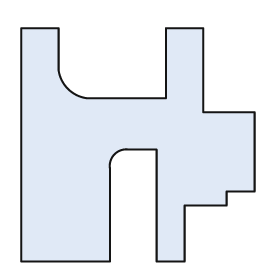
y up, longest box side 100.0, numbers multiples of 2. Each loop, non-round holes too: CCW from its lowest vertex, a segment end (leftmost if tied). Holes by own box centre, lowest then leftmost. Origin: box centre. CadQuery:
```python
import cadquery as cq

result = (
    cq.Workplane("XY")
    .moveTo(-50.0, -50.0)
    .lineTo(-12.0, -50.0)
    .lineTo(-12.0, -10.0)
    .threePointArc((-10.0, -4.0), (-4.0, -2.0))
    .lineTo(8.0, -2.0)
    .lineTo(8.0, -50.0)
    .lineTo(20.0, -50.0)
    .lineTo(20.0, -26.0)
    .lineTo(38.0, -26.0)
    .lineTo(38.0, -20.0)
    .lineTo(50.0, -20.0)
    .lineTo(50.0, 14.0)
    .lineTo(28.0, 14.0)
    .lineTo(28.0, 50.0)
    .lineTo(12.0, 50.0)
    .lineTo(12.0, 20.0)
    .lineTo(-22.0, 20.0)
    .threePointArc((-30.0, 24.0), (-34.0, 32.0))
    .lineTo(-34.0, 50.0)
    .lineTo(-50.0, 50.0)
    .close()
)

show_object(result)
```